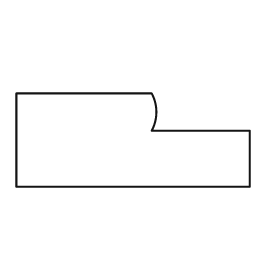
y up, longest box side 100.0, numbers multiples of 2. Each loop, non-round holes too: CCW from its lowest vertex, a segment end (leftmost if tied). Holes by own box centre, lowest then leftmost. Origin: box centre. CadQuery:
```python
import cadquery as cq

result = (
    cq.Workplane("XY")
    .moveTo(-50.0, -20.0)
    .lineTo(50.0, -20.0)
    .lineTo(50.0, 4.0)
    .lineTo(8.0, 4.0)
    .threePointArc((10.0, 12.0), (8.0, 20.0))
    .lineTo(-50.0, 20.0)
    .close()
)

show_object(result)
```